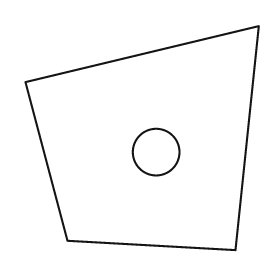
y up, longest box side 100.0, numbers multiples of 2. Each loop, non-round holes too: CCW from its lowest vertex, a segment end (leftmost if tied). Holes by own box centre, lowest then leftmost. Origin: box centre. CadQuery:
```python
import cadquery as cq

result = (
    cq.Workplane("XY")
    .moveTo(40.0, -48.0)
    .lineTo(50.0, 48.0)
    .lineTo(-50.0, 24.0)
    .lineTo(-32.0, -44.0)
    .close()
    .moveTo(6.0, -6.0)
    .circle(10.0)
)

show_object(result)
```